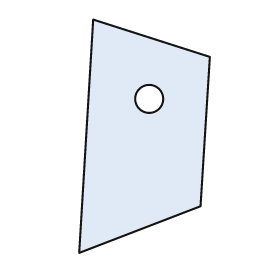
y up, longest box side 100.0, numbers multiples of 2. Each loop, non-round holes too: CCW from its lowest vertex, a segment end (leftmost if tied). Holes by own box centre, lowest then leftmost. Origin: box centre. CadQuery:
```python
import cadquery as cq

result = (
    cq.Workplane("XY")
    .moveTo(-28.0, -50.0)
    .lineTo(24.0, -30.0)
    .lineTo(28.0, 34.0)
    .lineTo(-22.0, 50.0)
    .close()
    .moveTo(2.0, 16.0)
    .circle(6.0)
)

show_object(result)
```